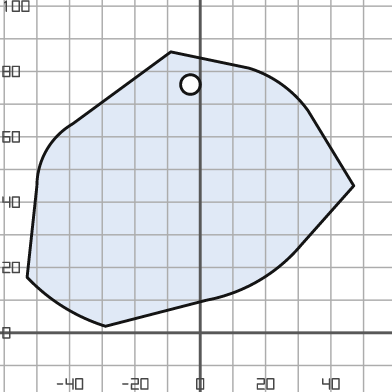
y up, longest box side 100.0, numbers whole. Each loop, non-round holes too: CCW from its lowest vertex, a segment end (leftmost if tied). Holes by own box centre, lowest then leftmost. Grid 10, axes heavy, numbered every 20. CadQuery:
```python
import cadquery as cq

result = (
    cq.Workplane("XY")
    .moveTo(-29.0, 2.0)
    .lineTo(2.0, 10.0)
    .threePointArc((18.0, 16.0), (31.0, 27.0))
    .lineTo(47.0, 45.0)
    .lineTo(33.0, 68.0)
    .threePointArc((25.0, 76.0), (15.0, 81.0))
    .lineTo(-9.0, 86.0)
    .lineTo(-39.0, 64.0)
    .threePointArc((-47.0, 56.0), (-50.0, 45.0))
    .lineTo(-53.0, 17.0)
    .threePointArc((-42.0, 8.0), (-29.0, 2.0))
    .close()
    .moveTo(-3.0, 76.0)
    .circle(3.0)
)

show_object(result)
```